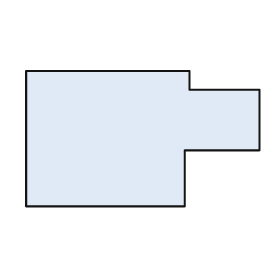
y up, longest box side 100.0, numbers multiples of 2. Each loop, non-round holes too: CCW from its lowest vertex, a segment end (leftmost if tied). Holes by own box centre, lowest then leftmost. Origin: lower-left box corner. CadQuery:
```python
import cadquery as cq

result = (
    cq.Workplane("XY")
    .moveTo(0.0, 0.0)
    .lineTo(68.0, 0.0)
    .lineTo(68.0, 24.0)
    .lineTo(100.0, 24.0)
    .lineTo(100.0, 50.0)
    .lineTo(70.0, 50.0)
    .lineTo(70.0, 58.0)
    .lineTo(0.0, 58.0)
    .close()
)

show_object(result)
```